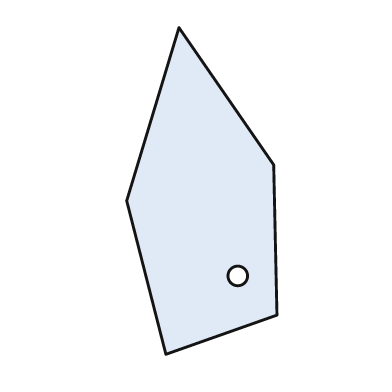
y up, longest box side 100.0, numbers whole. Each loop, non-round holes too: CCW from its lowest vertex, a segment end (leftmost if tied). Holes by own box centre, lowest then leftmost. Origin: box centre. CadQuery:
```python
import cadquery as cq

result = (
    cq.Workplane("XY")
    .moveTo(-11.0, -50.0)
    .lineTo(23.0, -38.0)
    .lineTo(22.0, 8.0)
    .lineTo(-7.0, 50.0)
    .lineTo(-23.0, -3.0)
    .close()
    .moveTo(11.0, -26.0)
    .circle(3.0)
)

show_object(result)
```